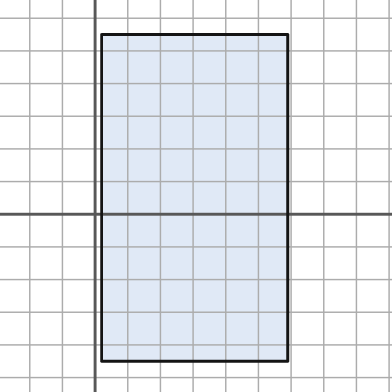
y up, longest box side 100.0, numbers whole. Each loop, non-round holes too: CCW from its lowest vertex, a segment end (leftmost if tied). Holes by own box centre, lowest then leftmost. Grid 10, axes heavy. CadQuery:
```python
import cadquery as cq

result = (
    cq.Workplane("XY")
    .moveTo(2.0, -45.0)
    .lineTo(59.0, -45.0)
    .lineTo(59.0, 55.0)
    .lineTo(2.0, 55.0)
    .close()
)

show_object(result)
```